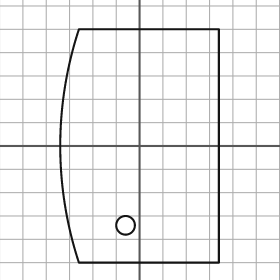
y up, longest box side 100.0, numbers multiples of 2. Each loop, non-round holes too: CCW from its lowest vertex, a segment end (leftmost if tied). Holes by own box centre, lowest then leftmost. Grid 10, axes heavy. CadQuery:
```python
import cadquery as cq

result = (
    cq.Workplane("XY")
    .moveTo(-26.0, -50.0)
    .lineTo(34.0, -50.0)
    .lineTo(34.0, 50.0)
    .lineTo(-26.0, 50.0)
    .threePointArc((-34.0, 0.0), (-26.0, -50.0))
    .close()
    .moveTo(-6.0, -34.0)
    .circle(4.0)
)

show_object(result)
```